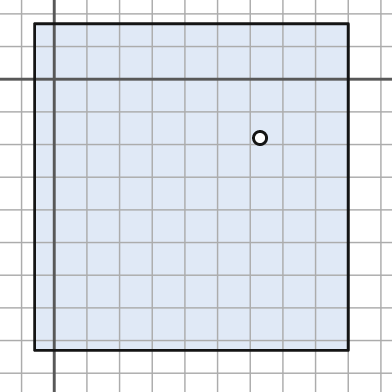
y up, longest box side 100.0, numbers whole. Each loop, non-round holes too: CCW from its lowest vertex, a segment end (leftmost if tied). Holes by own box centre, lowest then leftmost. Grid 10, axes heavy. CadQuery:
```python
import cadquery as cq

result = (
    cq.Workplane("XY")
    .moveTo(-6.0, -83.0)
    .lineTo(90.0, -83.0)
    .lineTo(90.0, 17.0)
    .lineTo(-6.0, 17.0)
    .close()
    .moveTo(63.0, -18.0)
    .circle(2.0)
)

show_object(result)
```